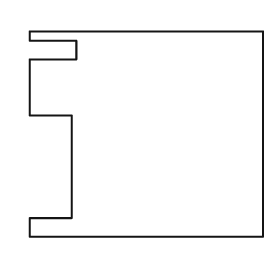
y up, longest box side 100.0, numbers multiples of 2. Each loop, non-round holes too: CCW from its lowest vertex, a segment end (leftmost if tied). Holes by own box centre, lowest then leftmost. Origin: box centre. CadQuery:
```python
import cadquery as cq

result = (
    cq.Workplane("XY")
    .moveTo(-50.0, -44.0)
    .lineTo(50.0, -44.0)
    .lineTo(50.0, 44.0)
    .lineTo(-50.0, 44.0)
    .lineTo(-50.0, 40.0)
    .lineTo(-30.0, 40.0)
    .lineTo(-30.0, 32.0)
    .lineTo(-50.0, 32.0)
    .lineTo(-50.0, 8.0)
    .lineTo(-32.0, 8.0)
    .lineTo(-32.0, -36.0)
    .lineTo(-50.0, -36.0)
    .close()
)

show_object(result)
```